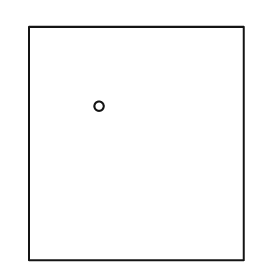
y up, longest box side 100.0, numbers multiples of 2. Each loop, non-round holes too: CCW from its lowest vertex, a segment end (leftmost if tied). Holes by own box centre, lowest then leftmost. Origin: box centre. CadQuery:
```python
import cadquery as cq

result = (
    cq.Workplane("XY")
    .moveTo(-46.0, -50.0)
    .lineTo(46.0, -50.0)
    .lineTo(46.0, 50.0)
    .lineTo(-46.0, 50.0)
    .close()
    .moveTo(-16.0, 16.0)
    .circle(2.0)
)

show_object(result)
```